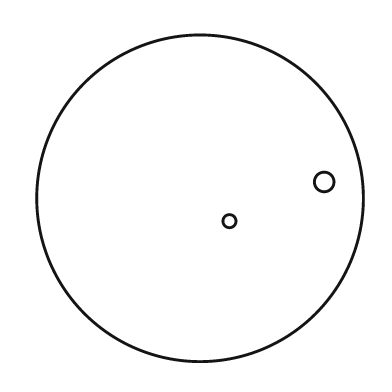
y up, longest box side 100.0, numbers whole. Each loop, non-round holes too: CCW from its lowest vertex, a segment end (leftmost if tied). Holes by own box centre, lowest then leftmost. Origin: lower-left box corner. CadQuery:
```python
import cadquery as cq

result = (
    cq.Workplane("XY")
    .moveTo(50.0, 50.0)
    .circle(50.0)
    .moveTo(59.0, 43.0)
    .circle(2.0)
    .moveTo(88.0, 55.0)
    .circle(3.0)
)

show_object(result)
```